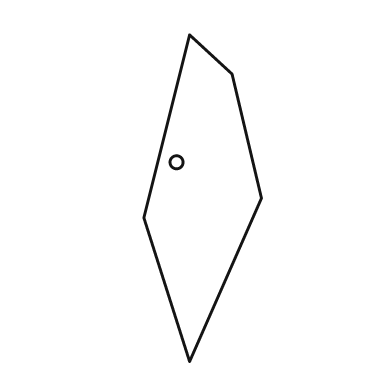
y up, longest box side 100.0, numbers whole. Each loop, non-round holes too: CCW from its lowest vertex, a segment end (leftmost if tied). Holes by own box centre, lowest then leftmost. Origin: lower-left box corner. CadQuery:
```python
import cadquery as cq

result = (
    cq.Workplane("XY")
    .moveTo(14.0, 0.0)
    .lineTo(36.0, 50.0)
    .lineTo(27.0, 88.0)
    .lineTo(14.0, 100.0)
    .lineTo(0.0, 44.0)
    .close()
    .moveTo(10.0, 61.0)
    .circle(2.0)
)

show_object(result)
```